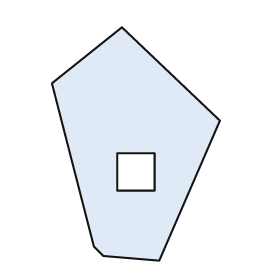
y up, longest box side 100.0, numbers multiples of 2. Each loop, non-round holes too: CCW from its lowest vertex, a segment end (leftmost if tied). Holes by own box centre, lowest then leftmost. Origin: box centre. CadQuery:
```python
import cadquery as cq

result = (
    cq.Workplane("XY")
    .moveTo(10.0, -50.0)
    .lineTo(36.0, 10.0)
    .lineTo(-6.0, 50.0)
    .lineTo(-36.0, 26.0)
    .lineTo(-18.0, -44.0)
    .lineTo(-14.0, -48.0)
    .close()
    .moveTo(-8.0, -20.0)
    .lineTo(8.0, -20.0)
    .lineTo(8.0, -4.0)
    .lineTo(-8.0, -4.0)
    .close()
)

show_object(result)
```